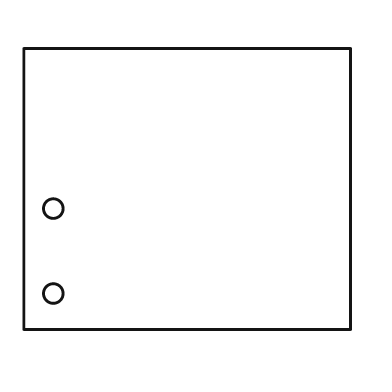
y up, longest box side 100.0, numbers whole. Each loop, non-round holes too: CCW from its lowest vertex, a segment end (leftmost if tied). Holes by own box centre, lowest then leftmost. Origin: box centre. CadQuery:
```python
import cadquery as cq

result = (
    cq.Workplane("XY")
    .moveTo(-50.0, -43.0)
    .lineTo(50.0, -43.0)
    .lineTo(50.0, 43.0)
    .lineTo(-50.0, 43.0)
    .close()
    .moveTo(-41.0, -32.0)
    .circle(3.0)
    .moveTo(-41.0, -6.0)
    .circle(3.0)
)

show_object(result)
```